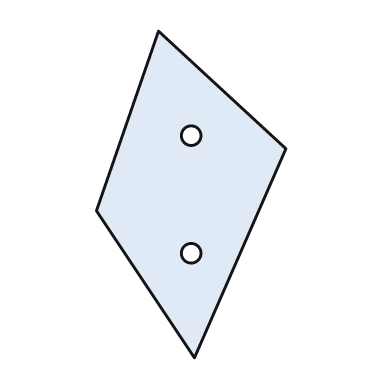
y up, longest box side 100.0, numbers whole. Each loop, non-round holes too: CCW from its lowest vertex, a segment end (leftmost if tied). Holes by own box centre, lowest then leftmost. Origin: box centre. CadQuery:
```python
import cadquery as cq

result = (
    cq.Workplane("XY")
    .moveTo(1.0, -50.0)
    .lineTo(29.0, 14.0)
    .lineTo(-10.0, 50.0)
    .lineTo(-29.0, -5.0)
    .close()
    .moveTo(0.0, -18.0)
    .circle(3.0)
    .moveTo(0.0, 18.0)
    .circle(3.0)
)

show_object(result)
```